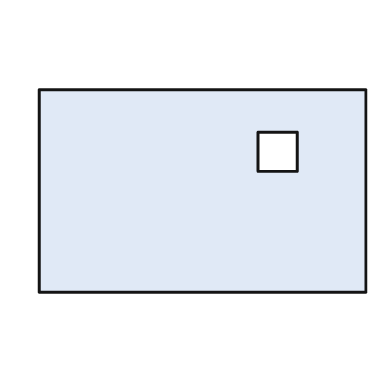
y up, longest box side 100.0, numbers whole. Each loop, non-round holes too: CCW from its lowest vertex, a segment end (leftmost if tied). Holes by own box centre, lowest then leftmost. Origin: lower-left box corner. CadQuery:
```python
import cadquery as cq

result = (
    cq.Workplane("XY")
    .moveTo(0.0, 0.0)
    .lineTo(100.0, 0.0)
    .lineTo(100.0, 62.0)
    .lineTo(0.0, 62.0)
    .close()
    .moveTo(67.0, 37.0)
    .lineTo(79.0, 37.0)
    .lineTo(79.0, 49.0)
    .lineTo(67.0, 49.0)
    .close()
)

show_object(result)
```